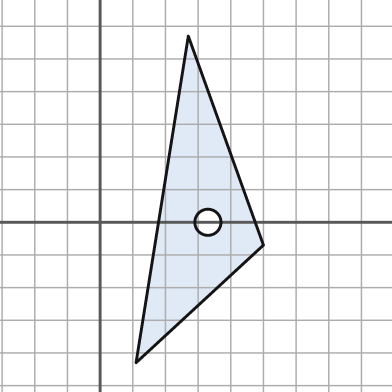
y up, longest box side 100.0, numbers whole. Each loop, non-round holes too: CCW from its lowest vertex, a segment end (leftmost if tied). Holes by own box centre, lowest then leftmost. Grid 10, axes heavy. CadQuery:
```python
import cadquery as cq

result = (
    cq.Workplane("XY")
    .moveTo(11.0, -43.0)
    .lineTo(50.0, -7.0)
    .lineTo(27.0, 57.0)
    .close()
    .moveTo(33.0, 0.0)
    .circle(4.0)
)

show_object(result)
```